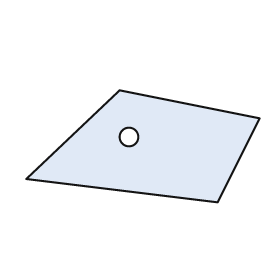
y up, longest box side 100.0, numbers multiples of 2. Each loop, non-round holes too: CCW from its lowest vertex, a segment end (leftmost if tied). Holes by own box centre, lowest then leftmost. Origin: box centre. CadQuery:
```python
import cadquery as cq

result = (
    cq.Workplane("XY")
    .moveTo(32.0, -24.0)
    .lineTo(50.0, 12.0)
    .lineTo(-10.0, 24.0)
    .lineTo(-50.0, -14.0)
    .close()
    .moveTo(-6.0, 4.0)
    .circle(4.0)
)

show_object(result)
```